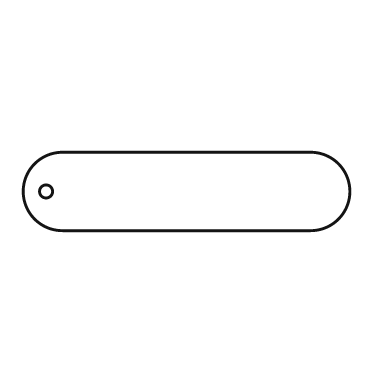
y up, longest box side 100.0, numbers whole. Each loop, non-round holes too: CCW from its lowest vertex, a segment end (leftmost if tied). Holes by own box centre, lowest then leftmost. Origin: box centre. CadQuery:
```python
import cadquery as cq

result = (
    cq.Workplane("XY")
    .moveTo(-38.0, -12.0)
    .lineTo(38.0, -12.0)
    .threePointArc((50.0, 0.0), (38.0, 12.0))
    .lineTo(-38.0, 12.0)
    .threePointArc((-50.0, 0.0), (-38.0, -12.0))
    .close()
    .moveTo(-43.0, 0.0)
    .circle(2.0)
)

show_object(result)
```